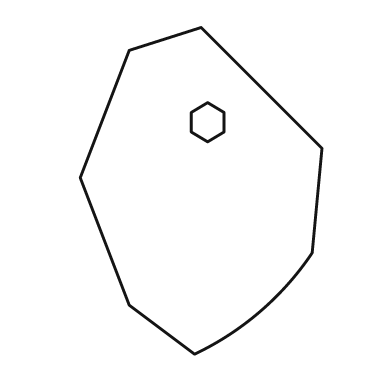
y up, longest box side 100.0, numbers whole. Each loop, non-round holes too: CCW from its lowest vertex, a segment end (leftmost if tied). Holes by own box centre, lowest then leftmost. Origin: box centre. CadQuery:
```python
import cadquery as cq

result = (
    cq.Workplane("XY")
    .moveTo(-2.0, -50.0)
    .threePointArc((18.0, -37.0), (34.0, -19.0))
    .lineTo(37.0, 13.0)
    .lineTo(0.0, 50.0)
    .lineTo(-22.0, 43.0)
    .lineTo(-37.0, 4.0)
    .lineTo(-22.0, -35.0)
    .close()
    .moveTo(2.0, 15.0)
    .lineTo(7.0, 18.0)
    .lineTo(7.0, 24.0)
    .lineTo(2.0, 27.0)
    .lineTo(-3.0, 24.0)
    .lineTo(-3.0, 18.0)
    .close()
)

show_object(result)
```